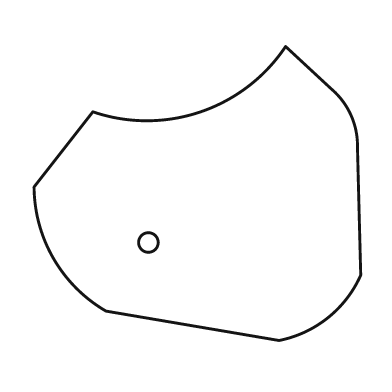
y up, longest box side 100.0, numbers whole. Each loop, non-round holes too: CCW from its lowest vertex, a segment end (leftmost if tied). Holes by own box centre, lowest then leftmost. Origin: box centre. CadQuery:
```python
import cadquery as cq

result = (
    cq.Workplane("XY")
    .moveTo(25.0, -45.0)
    .threePointArc((40.0, -38.0), (50.0, -25.0))
    .lineTo(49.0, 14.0)
    .threePointArc((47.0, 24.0), (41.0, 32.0))
    .lineTo(27.0, 45.0)
    .threePointArc((1.0, 25.0), (-32.0, 25.0))
    .lineTo(-50.0, 2.0)
    .threePointArc((-44.0, -20.0), (-28.0, -36.0))
    .close()
    .moveTo(-15.0, -15.0)
    .circle(3.0)
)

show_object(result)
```